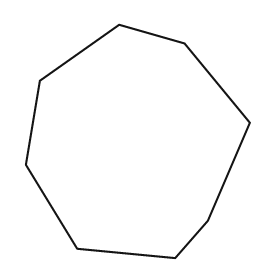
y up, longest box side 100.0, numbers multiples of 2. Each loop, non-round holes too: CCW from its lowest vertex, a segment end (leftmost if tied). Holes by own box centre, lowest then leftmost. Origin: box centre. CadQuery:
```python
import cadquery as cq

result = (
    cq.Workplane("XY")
    .moveTo(16.0, -50.0)
    .lineTo(30.0, -34.0)
    .lineTo(48.0, 8.0)
    .lineTo(20.0, 42.0)
    .lineTo(-8.0, 50.0)
    .lineTo(-42.0, 26.0)
    .lineTo(-48.0, -10.0)
    .lineTo(-26.0, -46.0)
    .close()
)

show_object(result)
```